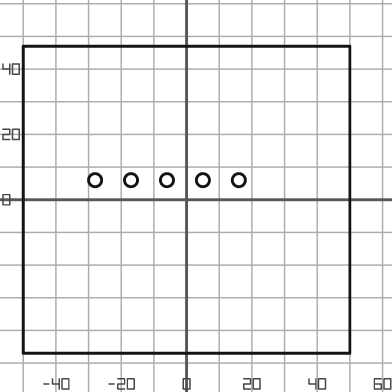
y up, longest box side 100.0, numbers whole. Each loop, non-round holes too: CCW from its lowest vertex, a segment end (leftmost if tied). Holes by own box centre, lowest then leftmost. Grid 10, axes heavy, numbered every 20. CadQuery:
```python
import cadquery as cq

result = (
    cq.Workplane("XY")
    .moveTo(-50.0, -47.0)
    .lineTo(50.0, -47.0)
    .lineTo(50.0, 47.0)
    .lineTo(-50.0, 47.0)
    .close()
    .moveTo(-28.0, 6.0)
    .circle(2.0)
    .moveTo(-17.0, 6.0)
    .circle(2.0)
    .moveTo(-6.0, 6.0)
    .circle(2.0)
    .moveTo(5.0, 6.0)
    .circle(2.0)
    .moveTo(16.0, 6.0)
    .circle(2.0)
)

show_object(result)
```